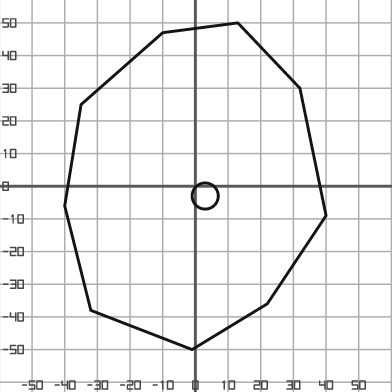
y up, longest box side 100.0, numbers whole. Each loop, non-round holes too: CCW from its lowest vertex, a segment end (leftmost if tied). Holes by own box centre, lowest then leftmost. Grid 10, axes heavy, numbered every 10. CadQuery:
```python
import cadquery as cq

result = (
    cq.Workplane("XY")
    .moveTo(-1.0, -50.0)
    .lineTo(22.0, -36.0)
    .lineTo(40.0, -9.0)
    .lineTo(32.0, 30.0)
    .lineTo(13.0, 50.0)
    .lineTo(-10.0, 47.0)
    .lineTo(-35.0, 25.0)
    .lineTo(-40.0, -6.0)
    .lineTo(-32.0, -38.0)
    .close()
    .moveTo(3.0, -3.0)
    .circle(4.0)
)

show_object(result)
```